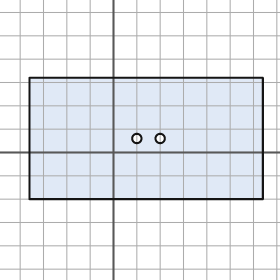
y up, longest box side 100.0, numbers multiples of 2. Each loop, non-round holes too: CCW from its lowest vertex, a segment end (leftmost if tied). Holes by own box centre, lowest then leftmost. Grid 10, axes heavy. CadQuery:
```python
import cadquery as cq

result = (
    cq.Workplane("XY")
    .moveTo(-36.0, -20.0)
    .lineTo(64.0, -20.0)
    .lineTo(64.0, 32.0)
    .lineTo(-36.0, 32.0)
    .close()
    .moveTo(10.0, 6.0)
    .circle(2.0)
    .moveTo(20.0, 6.0)
    .circle(2.0)
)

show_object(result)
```